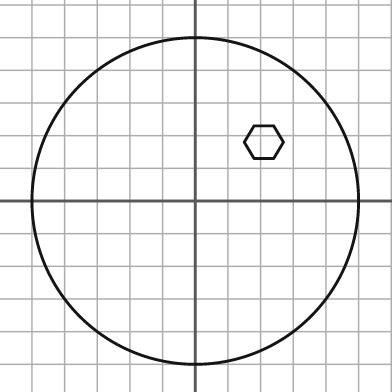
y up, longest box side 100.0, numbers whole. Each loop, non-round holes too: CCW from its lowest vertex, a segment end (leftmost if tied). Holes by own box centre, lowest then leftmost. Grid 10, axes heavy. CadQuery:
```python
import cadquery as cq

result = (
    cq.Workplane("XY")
    .moveTo(0.0, 0.0)
    .circle(50.0)
    .moveTo(18.0, 13.0)
    .lineTo(24.0, 13.0)
    .lineTo(27.0, 18.0)
    .lineTo(24.0, 23.0)
    .lineTo(18.0, 23.0)
    .lineTo(15.0, 18.0)
    .close()
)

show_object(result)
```